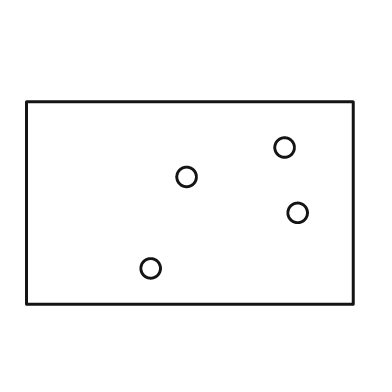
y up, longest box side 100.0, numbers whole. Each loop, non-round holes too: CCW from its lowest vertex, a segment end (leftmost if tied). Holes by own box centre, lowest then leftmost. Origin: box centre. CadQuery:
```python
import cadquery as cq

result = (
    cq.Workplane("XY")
    .moveTo(-50.0, -31.0)
    .lineTo(50.0, -31.0)
    .lineTo(50.0, 31.0)
    .lineTo(-50.0, 31.0)
    .close()
    .moveTo(-12.0, -20.0)
    .circle(3.0)
    .moveTo(33.0, -3.0)
    .circle(3.0)
    .moveTo(-1.0, 8.0)
    .circle(3.0)
    .moveTo(29.0, 17.0)
    .circle(3.0)
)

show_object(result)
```